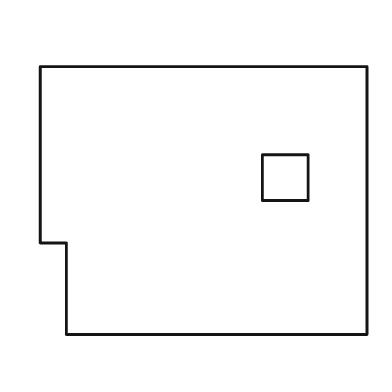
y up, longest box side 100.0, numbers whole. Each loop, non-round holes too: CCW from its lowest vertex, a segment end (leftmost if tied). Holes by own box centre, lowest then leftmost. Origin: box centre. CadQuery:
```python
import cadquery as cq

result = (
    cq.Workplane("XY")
    .moveTo(-42.0, -41.0)
    .lineTo(50.0, -41.0)
    .lineTo(50.0, 41.0)
    .lineTo(-50.0, 41.0)
    .lineTo(-50.0, -13.0)
    .lineTo(-42.0, -13.0)
    .close()
    .moveTo(18.0, 0.0)
    .lineTo(32.0, 0.0)
    .lineTo(32.0, 14.0)
    .lineTo(18.0, 14.0)
    .close()
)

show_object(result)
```